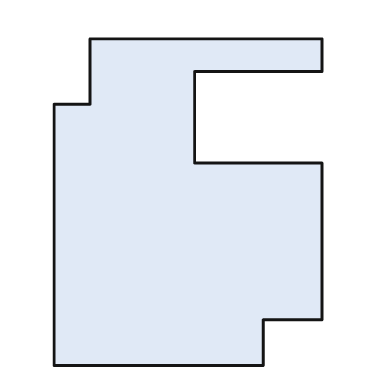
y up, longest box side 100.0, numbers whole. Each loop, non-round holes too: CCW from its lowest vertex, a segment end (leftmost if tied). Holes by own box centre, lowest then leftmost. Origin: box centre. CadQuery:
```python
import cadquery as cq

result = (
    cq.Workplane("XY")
    .moveTo(-41.0, -50.0)
    .lineTo(23.0, -50.0)
    .lineTo(23.0, -36.0)
    .lineTo(41.0, -36.0)
    .lineTo(41.0, 12.0)
    .lineTo(2.0, 12.0)
    .lineTo(2.0, 40.0)
    .lineTo(41.0, 40.0)
    .lineTo(41.0, 50.0)
    .lineTo(-30.0, 50.0)
    .lineTo(-30.0, 30.0)
    .lineTo(-41.0, 30.0)
    .close()
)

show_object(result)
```